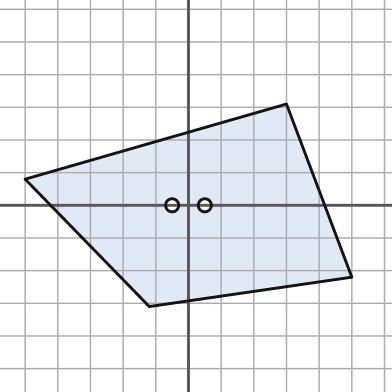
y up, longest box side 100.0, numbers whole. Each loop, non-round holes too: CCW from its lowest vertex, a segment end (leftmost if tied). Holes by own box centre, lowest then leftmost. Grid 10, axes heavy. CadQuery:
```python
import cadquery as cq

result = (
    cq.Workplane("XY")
    .moveTo(-12.0, -31.0)
    .lineTo(50.0, -22.0)
    .lineTo(30.0, 31.0)
    .lineTo(-50.0, 8.0)
    .close()
    .moveTo(-5.0, 0.0)
    .circle(2.0)
    .moveTo(5.0, 0.0)
    .circle(2.0)
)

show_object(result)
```